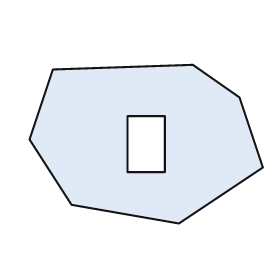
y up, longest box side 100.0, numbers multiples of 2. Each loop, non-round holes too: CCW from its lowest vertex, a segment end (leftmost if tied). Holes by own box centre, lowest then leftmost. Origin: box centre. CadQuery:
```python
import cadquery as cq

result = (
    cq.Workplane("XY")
    .moveTo(14.0, -34.0)
    .lineTo(50.0, -10.0)
    .lineTo(40.0, 20.0)
    .lineTo(20.0, 34.0)
    .lineTo(-40.0, 32.0)
    .lineTo(-50.0, 2.0)
    .lineTo(-32.0, -26.0)
    .close()
    .moveTo(-8.0, -12.0)
    .lineTo(8.0, -12.0)
    .lineTo(8.0, 12.0)
    .lineTo(-8.0, 12.0)
    .close()
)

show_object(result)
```